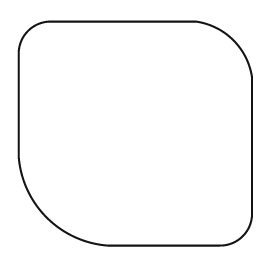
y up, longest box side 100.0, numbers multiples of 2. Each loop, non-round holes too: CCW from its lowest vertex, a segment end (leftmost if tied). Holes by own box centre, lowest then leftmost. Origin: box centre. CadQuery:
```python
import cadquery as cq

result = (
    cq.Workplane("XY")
    .moveTo(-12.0, -48.0)
    .lineTo(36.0, -48.0)
    .threePointArc((46.0, -44.0), (50.0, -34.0))
    .lineTo(50.0, 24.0)
    .threePointArc((42.0, 40.0), (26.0, 48.0))
    .lineTo(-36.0, 48.0)
    .threePointArc((-46.0, 44.0), (-50.0, 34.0))
    .lineTo(-50.0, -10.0)
    .threePointArc((-38.0, -36.0), (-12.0, -48.0))
    .close()
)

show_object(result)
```